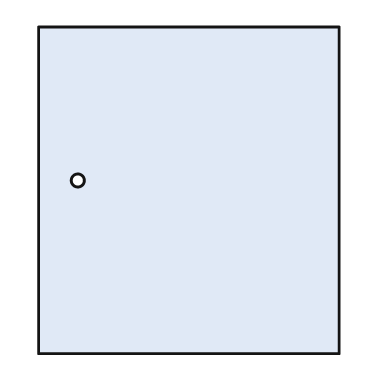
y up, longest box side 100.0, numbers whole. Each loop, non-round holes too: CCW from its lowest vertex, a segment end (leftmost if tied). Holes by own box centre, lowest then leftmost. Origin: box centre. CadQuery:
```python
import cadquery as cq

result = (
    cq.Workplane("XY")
    .moveTo(-46.0, -50.0)
    .lineTo(46.0, -50.0)
    .lineTo(46.0, 50.0)
    .lineTo(-46.0, 50.0)
    .close()
    .moveTo(-34.0, 3.0)
    .circle(2.0)
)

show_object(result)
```